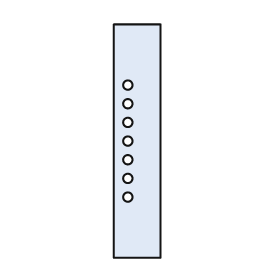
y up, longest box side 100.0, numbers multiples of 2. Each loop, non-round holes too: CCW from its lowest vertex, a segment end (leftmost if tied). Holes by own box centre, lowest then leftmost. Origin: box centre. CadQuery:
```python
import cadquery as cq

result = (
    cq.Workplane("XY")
    .moveTo(-10.0, -50.0)
    .lineTo(10.0, -50.0)
    .lineTo(10.0, 50.0)
    .lineTo(-10.0, 50.0)
    .close()
    .moveTo(-4.0, -24.0)
    .circle(2.0)
    .moveTo(-4.0, -16.0)
    .circle(2.0)
    .moveTo(-4.0, -8.0)
    .circle(2.0)
    .moveTo(-4.0, 0.0)
    .circle(2.0)
    .moveTo(-4.0, 8.0)
    .circle(2.0)
    .moveTo(-4.0, 16.0)
    .circle(2.0)
    .moveTo(-4.0, 24.0)
    .circle(2.0)
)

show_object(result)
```